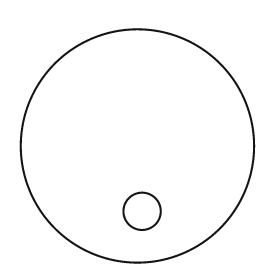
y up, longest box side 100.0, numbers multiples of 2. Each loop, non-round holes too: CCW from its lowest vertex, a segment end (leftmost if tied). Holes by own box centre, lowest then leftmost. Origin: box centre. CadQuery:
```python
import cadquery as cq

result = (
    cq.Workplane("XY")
    .moveTo(0.0, 0.0)
    .circle(50.0)
    .moveTo(2.0, -28.0)
    .circle(8.0)
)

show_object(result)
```